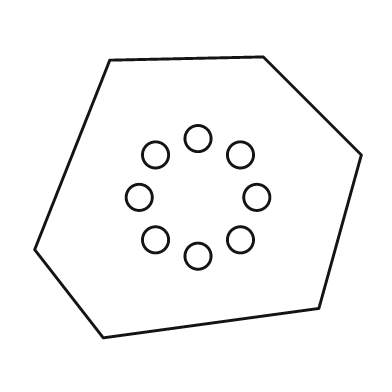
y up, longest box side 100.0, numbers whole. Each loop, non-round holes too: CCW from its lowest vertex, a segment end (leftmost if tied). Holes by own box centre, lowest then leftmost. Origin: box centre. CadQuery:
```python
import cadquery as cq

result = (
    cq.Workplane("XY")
    .moveTo(-29.0, -43.0)
    .lineTo(37.0, -34.0)
    .lineTo(50.0, 13.0)
    .lineTo(20.0, 43.0)
    .lineTo(-27.0, 42.0)
    .lineTo(-50.0, -16.0)
    .close()
    .moveTo(0.0, -18.0)
    .circle(4.0)
    .moveTo(-13.0, -13.0)
    .circle(4.0)
    .moveTo(13.0, -13.0)
    .circle(4.0)
    .moveTo(-18.0, 0.0)
    .circle(4.0)
    .moveTo(18.0, 0.0)
    .circle(4.0)
    .moveTo(-13.0, 13.0)
    .circle(4.0)
    .moveTo(13.0, 13.0)
    .circle(4.0)
    .moveTo(0.0, 18.0)
    .circle(4.0)
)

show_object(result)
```